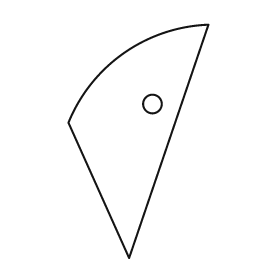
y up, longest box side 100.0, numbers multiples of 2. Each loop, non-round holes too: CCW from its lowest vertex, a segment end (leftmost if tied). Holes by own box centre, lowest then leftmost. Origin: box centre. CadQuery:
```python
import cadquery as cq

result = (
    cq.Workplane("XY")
    .moveTo(-4.0, -50.0)
    .lineTo(30.0, 50.0)
    .threePointArc((-6.0, 38.0), (-30.0, 8.0))
    .close()
    .moveTo(6.0, 16.0)
    .circle(4.0)
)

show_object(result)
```